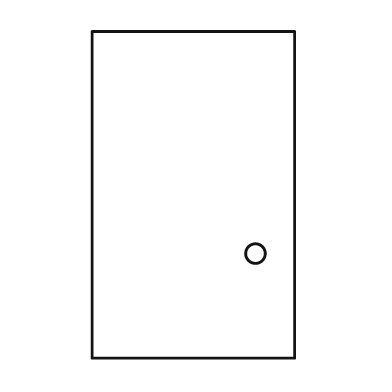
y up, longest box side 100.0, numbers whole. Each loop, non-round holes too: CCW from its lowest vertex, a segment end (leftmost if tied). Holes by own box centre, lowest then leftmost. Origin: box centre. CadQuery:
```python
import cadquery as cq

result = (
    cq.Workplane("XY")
    .moveTo(-31.0, -50.0)
    .lineTo(31.0, -50.0)
    .lineTo(31.0, 50.0)
    .lineTo(-31.0, 50.0)
    .close()
    .moveTo(19.0, -18.0)
    .circle(3.0)
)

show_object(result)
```